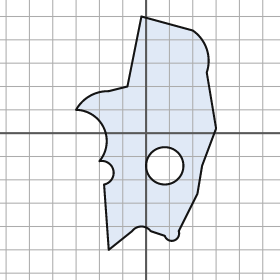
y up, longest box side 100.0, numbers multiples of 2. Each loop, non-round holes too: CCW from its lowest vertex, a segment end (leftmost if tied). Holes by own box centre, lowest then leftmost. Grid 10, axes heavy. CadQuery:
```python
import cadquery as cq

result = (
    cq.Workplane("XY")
    .moveTo(-16.0, -50.0)
    .lineTo(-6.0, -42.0)
    .threePointArc((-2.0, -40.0), (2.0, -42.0))
    .lineTo(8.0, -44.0)
    .threePointArc((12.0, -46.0), (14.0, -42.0))
    .lineTo(22.0, -26.0)
    .lineTo(24.0, -14.0)
    .lineTo(30.0, 2.0)
    .lineTo(26.0, 26.0)
    .threePointArc((26.0, 36.0), (20.0, 44.0))
    .lineTo(-2.0, 50.0)
    .lineTo(-8.0, 20.0)
    .lineTo(-16.0, 18.0)
    .threePointArc((-24.0, 16.0), (-30.0, 10.0))
    .threePointArc((-18.0, 2.0), (-20.0, -12.0))
    .threePointArc((-14.0, -16.0), (-18.0, -22.0))
    .close()
    .moveTo(8.0, -14.0)
    .circle(8.0)
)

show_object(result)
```